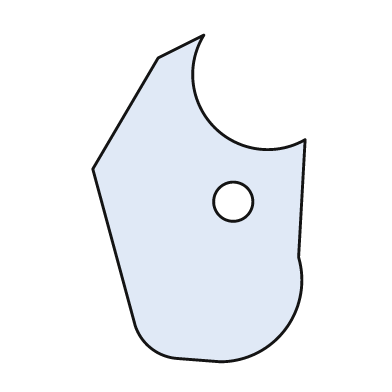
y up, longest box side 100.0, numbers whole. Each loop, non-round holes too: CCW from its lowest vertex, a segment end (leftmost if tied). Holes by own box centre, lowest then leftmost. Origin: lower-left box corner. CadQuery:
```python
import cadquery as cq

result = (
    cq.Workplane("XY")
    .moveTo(39.0, 0.0)
    .threePointArc((59.0, 10.0), (63.0, 32.0))
    .lineTo(65.0, 68.0)
    .threePointArc((37.0, 72.0), (34.0, 100.0))
    .lineTo(20.0, 93.0)
    .lineTo(0.0, 59.0)
    .lineTo(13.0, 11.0)
    .threePointArc((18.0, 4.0), (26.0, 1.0))
    .close()
    .moveTo(43.0, 49.0)
    .circle(6.0)
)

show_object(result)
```